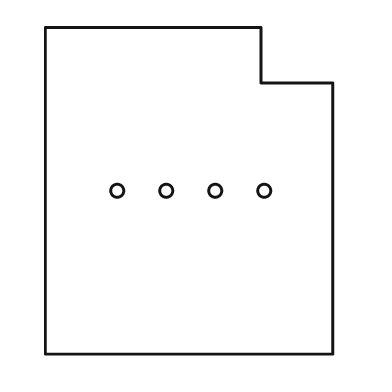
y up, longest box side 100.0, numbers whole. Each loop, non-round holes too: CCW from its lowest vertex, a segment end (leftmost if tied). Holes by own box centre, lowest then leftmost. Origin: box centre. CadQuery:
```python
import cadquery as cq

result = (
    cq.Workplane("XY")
    .moveTo(-44.0, -50.0)
    .lineTo(44.0, -50.0)
    .lineTo(44.0, 33.0)
    .lineTo(22.0, 33.0)
    .lineTo(22.0, 50.0)
    .lineTo(-44.0, 50.0)
    .close()
    .moveTo(-22.0, 0.0)
    .circle(2.0)
    .moveTo(-7.0, 0.0)
    .circle(2.0)
    .moveTo(8.0, 0.0)
    .circle(2.0)
    .moveTo(23.0, 0.0)
    .circle(2.0)
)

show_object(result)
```